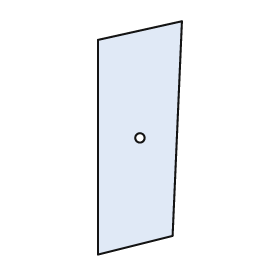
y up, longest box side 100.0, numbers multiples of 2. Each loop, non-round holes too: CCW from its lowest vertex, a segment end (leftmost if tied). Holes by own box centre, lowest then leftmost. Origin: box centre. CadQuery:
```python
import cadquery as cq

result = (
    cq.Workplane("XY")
    .moveTo(-18.0, -50.0)
    .lineTo(14.0, -42.0)
    .lineTo(18.0, 50.0)
    .lineTo(-18.0, 42.0)
    .close()
    .moveTo(0.0, 0.0)
    .circle(2.0)
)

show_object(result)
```